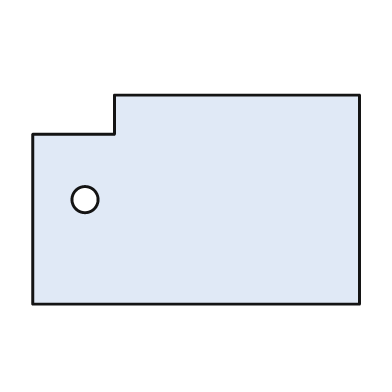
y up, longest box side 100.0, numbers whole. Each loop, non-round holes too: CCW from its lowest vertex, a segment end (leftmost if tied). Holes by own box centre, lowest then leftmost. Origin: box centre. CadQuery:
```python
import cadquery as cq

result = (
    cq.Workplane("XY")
    .moveTo(-50.0, -32.0)
    .lineTo(50.0, -32.0)
    .lineTo(50.0, 32.0)
    .lineTo(-25.0, 32.0)
    .lineTo(-25.0, 20.0)
    .lineTo(-50.0, 20.0)
    .close()
    .moveTo(-34.0, 0.0)
    .circle(4.0)
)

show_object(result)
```